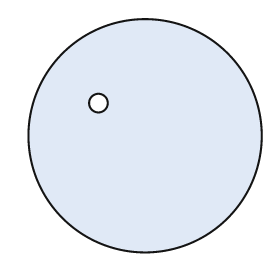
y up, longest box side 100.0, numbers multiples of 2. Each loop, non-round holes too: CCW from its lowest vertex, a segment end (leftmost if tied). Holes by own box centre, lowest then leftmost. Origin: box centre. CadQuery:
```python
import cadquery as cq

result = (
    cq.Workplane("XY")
    .moveTo(0.0, 0.0)
    .circle(50.0)
    .moveTo(-20.0, 14.0)
    .circle(4.0)
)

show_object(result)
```